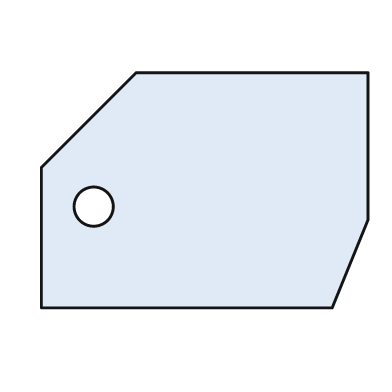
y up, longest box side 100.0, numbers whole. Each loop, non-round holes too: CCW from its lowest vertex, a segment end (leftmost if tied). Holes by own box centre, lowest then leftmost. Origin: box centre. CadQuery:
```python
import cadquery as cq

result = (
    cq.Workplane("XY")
    .moveTo(-50.0, -36.0)
    .lineTo(39.0, -36.0)
    .lineTo(50.0, -9.0)
    .lineTo(50.0, 36.0)
    .lineTo(-21.0, 36.0)
    .lineTo(-50.0, 7.0)
    .close()
    .moveTo(-34.0, -5.0)
    .circle(6.0)
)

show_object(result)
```